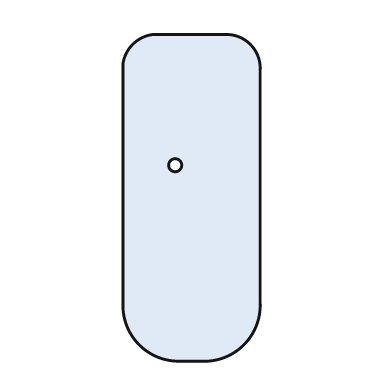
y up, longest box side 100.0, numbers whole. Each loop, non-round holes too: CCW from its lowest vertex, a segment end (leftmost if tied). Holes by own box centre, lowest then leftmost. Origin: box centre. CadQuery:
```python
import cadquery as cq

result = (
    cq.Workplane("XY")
    .moveTo(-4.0, -50.0)
    .lineTo(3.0, -50.0)
    .threePointArc((16.0, -45.0), (21.0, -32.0))
    .lineTo(21.0, 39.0)
    .threePointArc((18.0, 47.0), (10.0, 50.0))
    .lineTo(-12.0, 50.0)
    .threePointArc((-18.0, 47.0), (-21.0, 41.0))
    .lineTo(-21.0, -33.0)
    .threePointArc((-16.0, -45.0), (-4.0, -50.0))
    .close()
    .moveTo(-5.0, 10.0)
    .circle(2.0)
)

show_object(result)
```